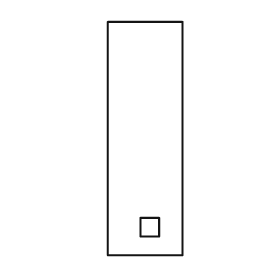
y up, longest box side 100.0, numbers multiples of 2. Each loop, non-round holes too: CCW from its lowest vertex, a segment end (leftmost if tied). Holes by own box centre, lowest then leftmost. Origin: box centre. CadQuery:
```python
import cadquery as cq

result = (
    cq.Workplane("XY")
    .moveTo(-16.0, -50.0)
    .lineTo(16.0, -50.0)
    .lineTo(16.0, 50.0)
    .lineTo(-16.0, 50.0)
    .close()
    .moveTo(-2.0, -42.0)
    .lineTo(6.0, -42.0)
    .lineTo(6.0, -34.0)
    .lineTo(-2.0, -34.0)
    .close()
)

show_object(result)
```